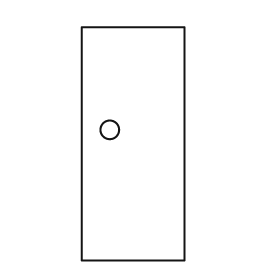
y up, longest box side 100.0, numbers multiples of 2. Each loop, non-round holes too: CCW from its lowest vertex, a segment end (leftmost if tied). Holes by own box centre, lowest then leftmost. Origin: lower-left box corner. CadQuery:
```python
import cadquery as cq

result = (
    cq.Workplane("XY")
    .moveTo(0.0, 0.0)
    .lineTo(44.0, 0.0)
    .lineTo(44.0, 100.0)
    .lineTo(0.0, 100.0)
    .close()
    .moveTo(12.0, 56.0)
    .circle(4.0)
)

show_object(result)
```